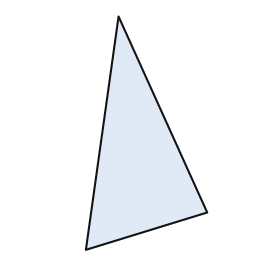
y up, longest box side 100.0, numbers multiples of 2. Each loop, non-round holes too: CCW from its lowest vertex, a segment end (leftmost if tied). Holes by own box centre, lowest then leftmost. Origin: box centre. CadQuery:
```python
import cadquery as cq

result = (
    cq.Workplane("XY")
    .moveTo(-26.0, -50.0)
    .lineTo(26.0, -34.0)
    .lineTo(-12.0, 50.0)
    .close()
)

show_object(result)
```